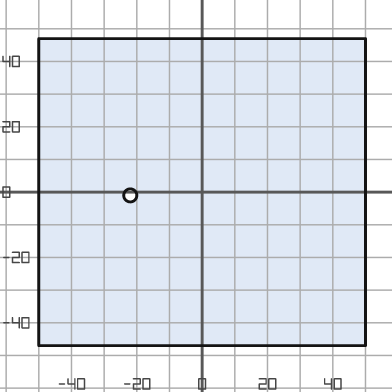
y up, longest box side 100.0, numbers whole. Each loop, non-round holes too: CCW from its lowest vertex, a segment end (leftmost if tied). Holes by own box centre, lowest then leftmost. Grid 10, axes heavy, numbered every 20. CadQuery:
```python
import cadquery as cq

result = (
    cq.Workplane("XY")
    .moveTo(-50.0, -47.0)
    .lineTo(50.0, -47.0)
    .lineTo(50.0, 47.0)
    .lineTo(-50.0, 47.0)
    .close()
    .moveTo(-22.0, -1.0)
    .circle(2.0)
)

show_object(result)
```